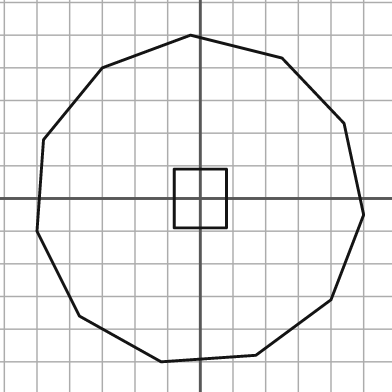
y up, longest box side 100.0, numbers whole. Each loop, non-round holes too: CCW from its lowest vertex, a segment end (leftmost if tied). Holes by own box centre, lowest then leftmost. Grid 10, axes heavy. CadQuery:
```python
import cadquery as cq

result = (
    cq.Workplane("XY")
    .moveTo(-12.0, -50.0)
    .lineTo(17.0, -48.0)
    .lineTo(40.0, -31.0)
    .lineTo(50.0, -5.0)
    .lineTo(44.0, 23.0)
    .lineTo(25.0, 43.0)
    .lineTo(-3.0, 50.0)
    .lineTo(-30.0, 40.0)
    .lineTo(-48.0, 18.0)
    .lineTo(-50.0, -10.0)
    .lineTo(-37.0, -36.0)
    .close()
    .moveTo(-8.0, -9.0)
    .lineTo(8.0, -9.0)
    .lineTo(8.0, 9.0)
    .lineTo(-8.0, 9.0)
    .close()
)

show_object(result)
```